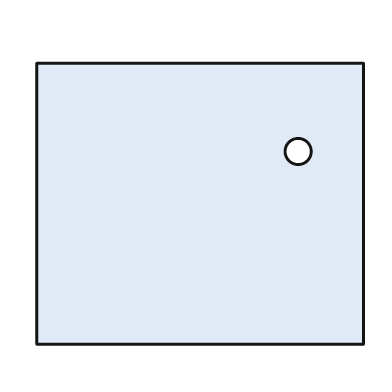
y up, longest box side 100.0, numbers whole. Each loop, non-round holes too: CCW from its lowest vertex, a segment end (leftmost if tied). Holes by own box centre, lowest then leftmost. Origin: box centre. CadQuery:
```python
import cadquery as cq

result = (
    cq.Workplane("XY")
    .moveTo(-50.0, -43.0)
    .lineTo(50.0, -43.0)
    .lineTo(50.0, 43.0)
    .lineTo(-50.0, 43.0)
    .close()
    .moveTo(30.0, 16.0)
    .circle(4.0)
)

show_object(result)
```